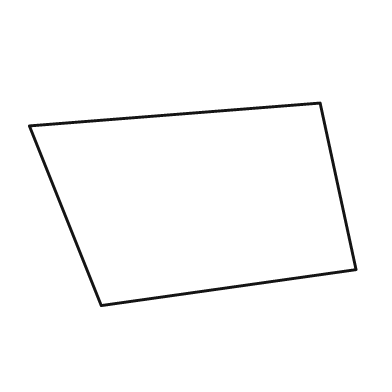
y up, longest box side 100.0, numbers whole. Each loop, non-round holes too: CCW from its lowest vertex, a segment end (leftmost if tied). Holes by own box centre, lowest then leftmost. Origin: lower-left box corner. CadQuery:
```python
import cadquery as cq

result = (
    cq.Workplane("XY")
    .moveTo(22.0, 0.0)
    .lineTo(100.0, 11.0)
    .lineTo(89.0, 62.0)
    .lineTo(0.0, 55.0)
    .close()
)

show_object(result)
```